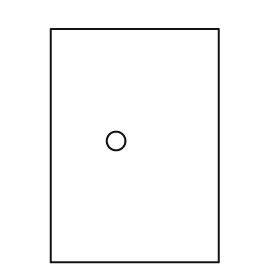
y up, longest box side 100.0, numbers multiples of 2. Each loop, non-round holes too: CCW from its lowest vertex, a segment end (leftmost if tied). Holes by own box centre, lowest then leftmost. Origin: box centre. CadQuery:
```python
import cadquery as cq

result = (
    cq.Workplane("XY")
    .moveTo(-36.0, -50.0)
    .lineTo(36.0, -50.0)
    .lineTo(36.0, 50.0)
    .lineTo(-36.0, 50.0)
    .close()
    .moveTo(-8.0, 2.0)
    .circle(4.0)
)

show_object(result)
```